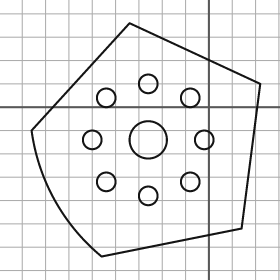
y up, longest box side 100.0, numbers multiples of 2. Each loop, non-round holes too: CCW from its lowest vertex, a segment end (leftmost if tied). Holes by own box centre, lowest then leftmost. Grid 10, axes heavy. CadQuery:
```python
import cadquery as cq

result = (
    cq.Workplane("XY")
    .moveTo(-46.0, -64.0)
    .lineTo(14.0, -52.0)
    .lineTo(22.0, 10.0)
    .lineTo(-34.0, 36.0)
    .lineTo(-76.0, -10.0)
    .threePointArc((-66.0, -40.0), (-46.0, -64.0))
    .close()
    .moveTo(-26.0, -38.0)
    .circle(4.0)
    .moveTo(-44.0, -32.0)
    .circle(4.0)
    .moveTo(-8.0, -32.0)
    .circle(4.0)
    .moveTo(-50.0, -14.0)
    .circle(4.0)
    .moveTo(-26.0, -14.0)
    .circle(8.0)
    .moveTo(-2.0, -14.0)
    .circle(4.0)
    .moveTo(-44.0, 4.0)
    .circle(4.0)
    .moveTo(-8.0, 4.0)
    .circle(4.0)
    .moveTo(-26.0, 10.0)
    .circle(4.0)
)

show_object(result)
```